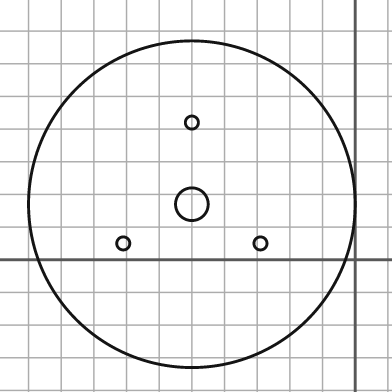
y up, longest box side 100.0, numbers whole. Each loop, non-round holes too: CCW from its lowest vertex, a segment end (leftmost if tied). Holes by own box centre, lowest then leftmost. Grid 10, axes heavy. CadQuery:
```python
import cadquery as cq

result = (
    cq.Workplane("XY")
    .moveTo(-50.0, 17.0)
    .circle(50.0)
    .moveTo(-71.0, 5.0)
    .circle(2.0)
    .moveTo(-29.0, 5.0)
    .circle(2.0)
    .moveTo(-50.0, 17.0)
    .circle(5.0)
    .moveTo(-50.0, 42.0)
    .circle(2.0)
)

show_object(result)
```